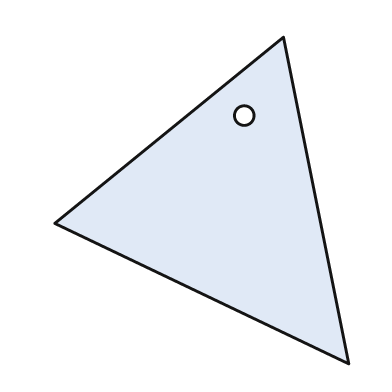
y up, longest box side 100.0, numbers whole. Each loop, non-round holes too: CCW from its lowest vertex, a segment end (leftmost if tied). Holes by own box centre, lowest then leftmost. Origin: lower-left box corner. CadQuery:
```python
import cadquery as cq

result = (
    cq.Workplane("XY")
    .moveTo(90.0, 0.0)
    .lineTo(70.0, 100.0)
    .lineTo(0.0, 43.0)
    .close()
    .moveTo(58.0, 76.0)
    .circle(3.0)
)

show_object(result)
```